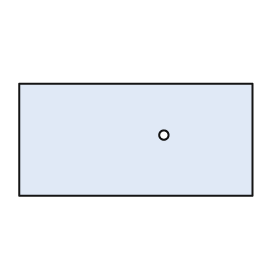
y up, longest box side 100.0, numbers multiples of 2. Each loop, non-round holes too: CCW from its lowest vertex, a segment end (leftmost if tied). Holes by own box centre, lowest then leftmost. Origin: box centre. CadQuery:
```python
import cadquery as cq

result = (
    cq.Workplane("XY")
    .moveTo(-50.0, -24.0)
    .lineTo(50.0, -24.0)
    .lineTo(50.0, 24.0)
    .lineTo(-50.0, 24.0)
    .close()
    .moveTo(12.0, 2.0)
    .circle(2.0)
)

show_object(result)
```